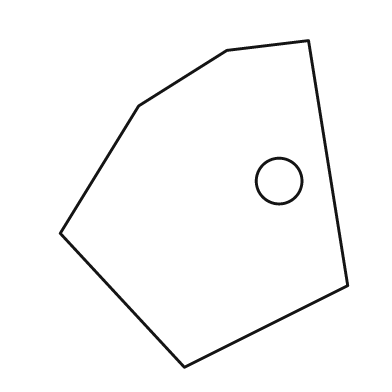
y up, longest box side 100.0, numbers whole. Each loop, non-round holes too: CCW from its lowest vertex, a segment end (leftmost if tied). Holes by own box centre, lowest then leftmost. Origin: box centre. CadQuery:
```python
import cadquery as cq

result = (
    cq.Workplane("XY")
    .moveTo(-6.0, -50.0)
    .lineTo(44.0, -25.0)
    .lineTo(32.0, 50.0)
    .lineTo(7.0, 47.0)
    .lineTo(-20.0, 30.0)
    .lineTo(-44.0, -9.0)
    .close()
    .moveTo(23.0, 7.0)
    .circle(7.0)
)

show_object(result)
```